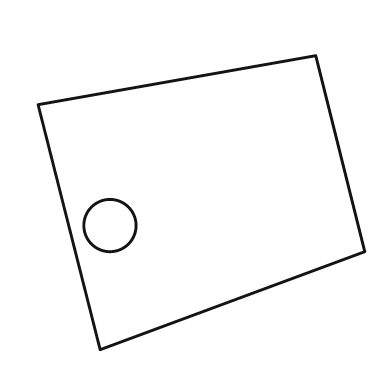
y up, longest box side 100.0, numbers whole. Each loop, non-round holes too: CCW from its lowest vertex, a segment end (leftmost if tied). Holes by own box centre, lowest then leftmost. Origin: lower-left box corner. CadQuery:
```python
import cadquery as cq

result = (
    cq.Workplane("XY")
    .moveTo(19.0, 0.0)
    .lineTo(100.0, 30.0)
    .lineTo(85.0, 90.0)
    .lineTo(0.0, 75.0)
    .close()
    .moveTo(22.0, 38.0)
    .circle(8.0)
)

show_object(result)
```